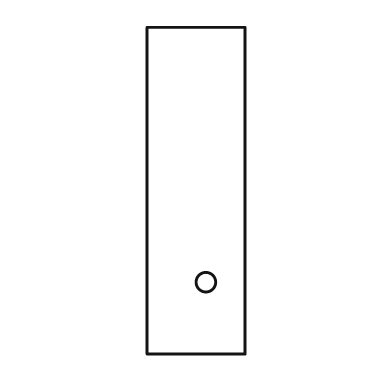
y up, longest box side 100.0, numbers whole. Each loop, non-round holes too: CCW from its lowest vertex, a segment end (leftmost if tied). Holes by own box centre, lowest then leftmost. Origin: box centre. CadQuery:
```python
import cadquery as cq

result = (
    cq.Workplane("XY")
    .moveTo(-15.0, -50.0)
    .lineTo(15.0, -50.0)
    .lineTo(15.0, 50.0)
    .lineTo(-15.0, 50.0)
    .close()
    .moveTo(3.0, -28.0)
    .circle(3.0)
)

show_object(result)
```